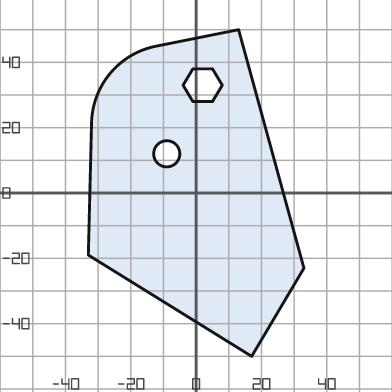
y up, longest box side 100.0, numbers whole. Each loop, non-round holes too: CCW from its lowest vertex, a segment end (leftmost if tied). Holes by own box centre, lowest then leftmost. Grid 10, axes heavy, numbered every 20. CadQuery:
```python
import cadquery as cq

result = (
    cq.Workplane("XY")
    .moveTo(17.0, -50.0)
    .lineTo(33.0, -23.0)
    .lineTo(13.0, 50.0)
    .lineTo(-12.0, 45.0)
    .threePointArc((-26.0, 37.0), (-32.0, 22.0))
    .lineTo(-33.0, -19.0)
    .close()
    .moveTo(-9.0, 12.0)
    .circle(4.0)
    .moveTo(-1.0, 28.0)
    .lineTo(5.0, 28.0)
    .lineTo(8.0, 33.0)
    .lineTo(5.0, 38.0)
    .lineTo(-1.0, 38.0)
    .lineTo(-4.0, 33.0)
    .close()
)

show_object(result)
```